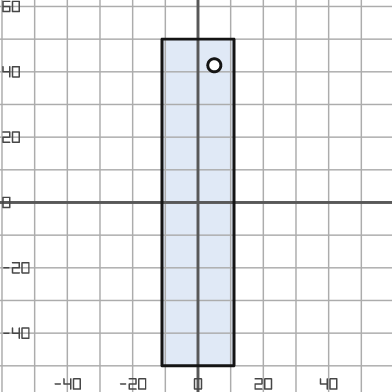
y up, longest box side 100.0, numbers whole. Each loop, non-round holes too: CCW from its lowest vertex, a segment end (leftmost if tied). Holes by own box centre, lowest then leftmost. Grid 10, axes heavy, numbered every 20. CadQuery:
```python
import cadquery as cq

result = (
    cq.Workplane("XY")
    .moveTo(-11.0, -50.0)
    .lineTo(11.0, -50.0)
    .lineTo(11.0, 50.0)
    .lineTo(-11.0, 50.0)
    .close()
    .moveTo(5.0, 42.0)
    .circle(2.0)
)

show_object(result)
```